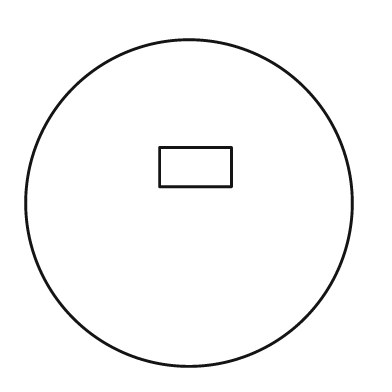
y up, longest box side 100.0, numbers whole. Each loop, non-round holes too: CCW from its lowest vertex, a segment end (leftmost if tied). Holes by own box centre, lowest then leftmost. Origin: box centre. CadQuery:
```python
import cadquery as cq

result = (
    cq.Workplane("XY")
    .moveTo(0.0, 0.0)
    .circle(50.0)
    .moveTo(-9.0, 5.0)
    .lineTo(13.0, 5.0)
    .lineTo(13.0, 17.0)
    .lineTo(-9.0, 17.0)
    .close()
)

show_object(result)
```